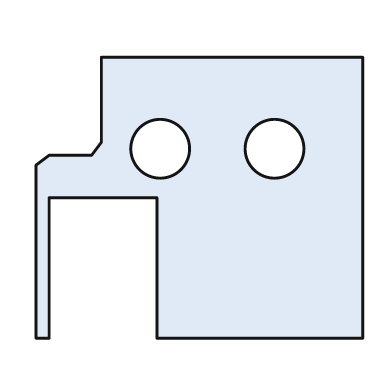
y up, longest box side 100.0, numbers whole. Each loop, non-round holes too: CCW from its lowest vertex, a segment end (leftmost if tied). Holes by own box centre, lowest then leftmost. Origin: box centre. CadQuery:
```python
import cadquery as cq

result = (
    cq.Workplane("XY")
    .moveTo(-50.0, -43.0)
    .lineTo(-46.0, -43.0)
    .lineTo(-46.0, 0.0)
    .lineTo(-13.0, 0.0)
    .lineTo(-13.0, -43.0)
    .lineTo(50.0, -43.0)
    .lineTo(50.0, 43.0)
    .lineTo(-30.0, 43.0)
    .lineTo(-30.0, 17.0)
    .lineTo(-33.0, 13.0)
    .lineTo(-46.0, 13.0)
    .lineTo(-50.0, 10.0)
    .close()
    .moveTo(-12.0, 15.0)
    .circle(9.0)
    .moveTo(23.0, 15.0)
    .circle(9.0)
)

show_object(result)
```